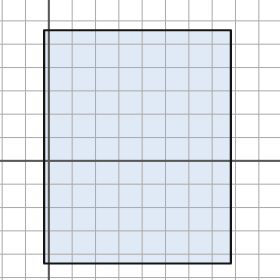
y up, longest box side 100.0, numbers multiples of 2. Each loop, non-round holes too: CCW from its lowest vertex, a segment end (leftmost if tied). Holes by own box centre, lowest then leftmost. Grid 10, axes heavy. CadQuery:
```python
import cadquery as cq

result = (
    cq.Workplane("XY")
    .moveTo(-2.0, -44.0)
    .lineTo(78.0, -44.0)
    .lineTo(78.0, 56.0)
    .lineTo(-2.0, 56.0)
    .close()
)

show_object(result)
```